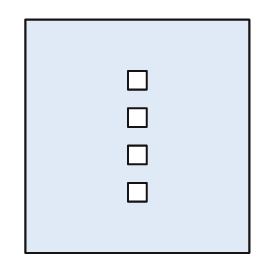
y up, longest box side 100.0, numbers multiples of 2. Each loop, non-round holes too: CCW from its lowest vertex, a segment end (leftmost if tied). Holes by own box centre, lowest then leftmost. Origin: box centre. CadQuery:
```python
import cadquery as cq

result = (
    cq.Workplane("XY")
    .moveTo(-48.0, -50.0)
    .lineTo(48.0, -50.0)
    .lineTo(48.0, 50.0)
    .lineTo(-48.0, 50.0)
    .close()
    .moveTo(-4.0, -28.0)
    .lineTo(4.0, -28.0)
    .lineTo(4.0, -20.0)
    .lineTo(-4.0, -20.0)
    .close()
    .moveTo(-4.0, -12.0)
    .lineTo(4.0, -12.0)
    .lineTo(4.0, -4.0)
    .lineTo(-4.0, -4.0)
    .close()
    .moveTo(-4.0, 4.0)
    .lineTo(4.0, 4.0)
    .lineTo(4.0, 12.0)
    .lineTo(-4.0, 12.0)
    .close()
    .moveTo(-4.0, 20.0)
    .lineTo(4.0, 20.0)
    .lineTo(4.0, 28.0)
    .lineTo(-4.0, 28.0)
    .close()
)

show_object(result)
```